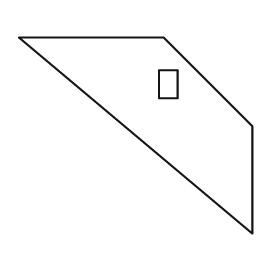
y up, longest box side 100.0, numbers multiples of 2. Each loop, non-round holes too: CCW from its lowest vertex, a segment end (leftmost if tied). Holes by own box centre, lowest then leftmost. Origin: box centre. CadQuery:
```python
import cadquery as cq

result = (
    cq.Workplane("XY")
    .moveTo(50.0, -42.0)
    .lineTo(50.0, 4.0)
    .lineTo(12.0, 42.0)
    .lineTo(-50.0, 42.0)
    .close()
    .moveTo(10.0, 16.0)
    .lineTo(18.0, 16.0)
    .lineTo(18.0, 28.0)
    .lineTo(10.0, 28.0)
    .close()
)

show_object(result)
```